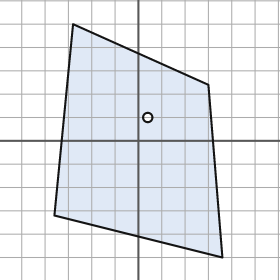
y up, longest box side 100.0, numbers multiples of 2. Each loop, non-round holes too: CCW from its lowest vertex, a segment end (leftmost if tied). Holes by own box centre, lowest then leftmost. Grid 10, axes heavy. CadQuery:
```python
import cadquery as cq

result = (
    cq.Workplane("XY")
    .moveTo(36.0, -50.0)
    .lineTo(30.0, 24.0)
    .lineTo(-28.0, 50.0)
    .lineTo(-36.0, -32.0)
    .close()
    .moveTo(4.0, 10.0)
    .circle(2.0)
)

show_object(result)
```